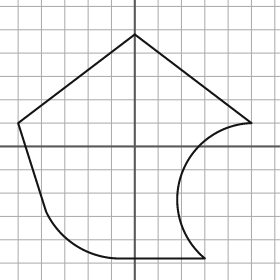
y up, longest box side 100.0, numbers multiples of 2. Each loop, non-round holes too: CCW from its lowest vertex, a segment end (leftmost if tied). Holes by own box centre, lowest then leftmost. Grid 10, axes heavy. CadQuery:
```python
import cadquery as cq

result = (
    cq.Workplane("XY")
    .moveTo(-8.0, -48.0)
    .lineTo(30.0, -48.0)
    .threePointArc((20.0, -12.0), (50.0, 10.0))
    .lineTo(0.0, 48.0)
    .lineTo(-50.0, 10.0)
    .lineTo(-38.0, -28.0)
    .threePointArc((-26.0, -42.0), (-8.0, -48.0))
    .close()
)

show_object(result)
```